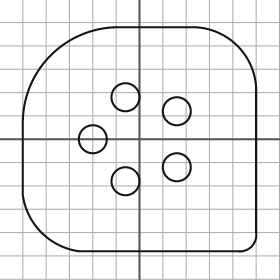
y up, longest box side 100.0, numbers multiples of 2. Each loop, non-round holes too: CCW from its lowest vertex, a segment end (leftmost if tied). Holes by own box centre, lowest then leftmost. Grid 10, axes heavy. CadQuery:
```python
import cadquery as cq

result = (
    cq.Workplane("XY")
    .moveTo(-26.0, -48.0)
    .lineTo(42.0, -48.0)
    .threePointArc((48.0, -46.0), (50.0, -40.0))
    .lineTo(50.0, 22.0)
    .threePointArc((42.0, 40.0), (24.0, 48.0))
    .lineTo(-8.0, 48.0)
    .threePointArc((-38.0, 36.0), (-50.0, 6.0))
    .lineTo(-50.0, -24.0)
    .threePointArc((-42.0, -40.0), (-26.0, -48.0))
    .close()
    .moveTo(-6.0, -18.0)
    .circle(6.0)
    .moveTo(16.0, -12.0)
    .circle(6.0)
    .moveTo(-20.0, 0.0)
    .circle(6.0)
    .moveTo(16.0, 12.0)
    .circle(6.0)
    .moveTo(-6.0, 18.0)
    .circle(6.0)
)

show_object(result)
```